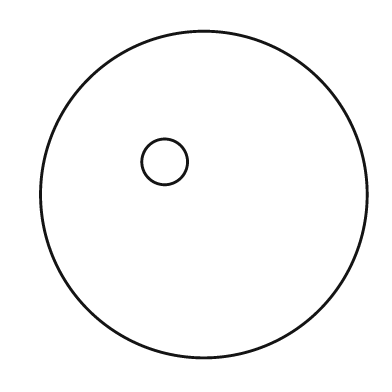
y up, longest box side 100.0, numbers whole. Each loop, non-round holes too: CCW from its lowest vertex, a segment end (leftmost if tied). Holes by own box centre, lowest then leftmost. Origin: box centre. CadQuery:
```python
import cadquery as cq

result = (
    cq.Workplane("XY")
    .moveTo(0.0, 0.0)
    .circle(50.0)
    .moveTo(-12.0, 10.0)
    .circle(7.0)
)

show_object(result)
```